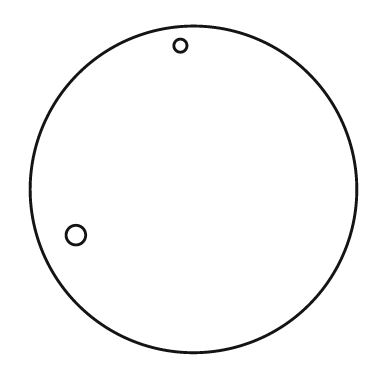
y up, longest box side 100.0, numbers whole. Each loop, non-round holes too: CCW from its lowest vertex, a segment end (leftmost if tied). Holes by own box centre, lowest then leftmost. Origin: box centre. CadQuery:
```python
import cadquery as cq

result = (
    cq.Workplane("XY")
    .moveTo(0.0, 0.0)
    .circle(50.0)
    .moveTo(-36.0, -14.0)
    .circle(3.0)
    .moveTo(-4.0, 44.0)
    .circle(2.0)
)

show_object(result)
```